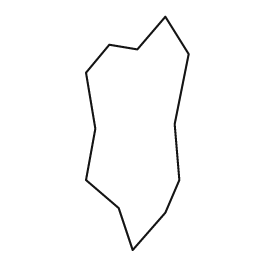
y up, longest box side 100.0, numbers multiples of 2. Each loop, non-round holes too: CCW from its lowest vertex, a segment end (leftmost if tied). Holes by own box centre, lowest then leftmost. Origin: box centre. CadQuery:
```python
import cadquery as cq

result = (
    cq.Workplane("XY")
    .moveTo(-2.0, -50.0)
    .lineTo(12.0, -34.0)
    .lineTo(18.0, -20.0)
    .lineTo(16.0, 4.0)
    .lineTo(22.0, 34.0)
    .lineTo(12.0, 50.0)
    .lineTo(0.0, 36.0)
    .lineTo(-12.0, 38.0)
    .lineTo(-22.0, 26.0)
    .lineTo(-18.0, 2.0)
    .lineTo(-22.0, -20.0)
    .lineTo(-8.0, -32.0)
    .close()
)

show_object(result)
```